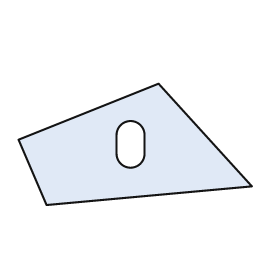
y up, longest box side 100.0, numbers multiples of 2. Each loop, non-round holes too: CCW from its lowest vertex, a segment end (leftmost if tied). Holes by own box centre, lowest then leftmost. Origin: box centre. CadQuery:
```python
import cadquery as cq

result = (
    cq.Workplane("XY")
    .moveTo(-38.0, -26.0)
    .lineTo(50.0, -18.0)
    .lineTo(10.0, 26.0)
    .lineTo(-50.0, 2.0)
    .close()
    .moveTo(-8.0, -4.0)
    .threePointArc((-2.0, -10.0), (4.0, -4.0))
    .lineTo(4.0, 4.0)
    .threePointArc((-2.0, 10.0), (-8.0, 4.0))
    .close()
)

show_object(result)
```